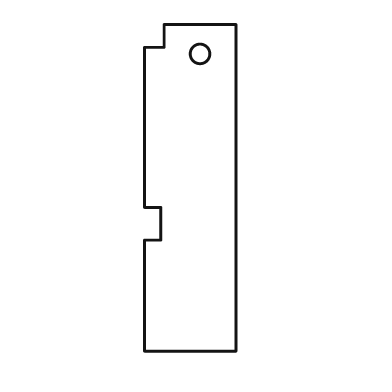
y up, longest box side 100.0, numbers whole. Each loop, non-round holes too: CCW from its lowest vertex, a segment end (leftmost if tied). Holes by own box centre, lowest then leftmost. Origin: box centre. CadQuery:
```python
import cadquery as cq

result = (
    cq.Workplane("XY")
    .moveTo(-14.0, -50.0)
    .lineTo(14.0, -50.0)
    .lineTo(14.0, 50.0)
    .lineTo(-8.0, 50.0)
    .lineTo(-8.0, 43.0)
    .lineTo(-14.0, 43.0)
    .lineTo(-14.0, -6.0)
    .lineTo(-9.0, -6.0)
    .lineTo(-9.0, -16.0)
    .lineTo(-14.0, -16.0)
    .close()
    .moveTo(3.0, 41.0)
    .circle(3.0)
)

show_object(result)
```